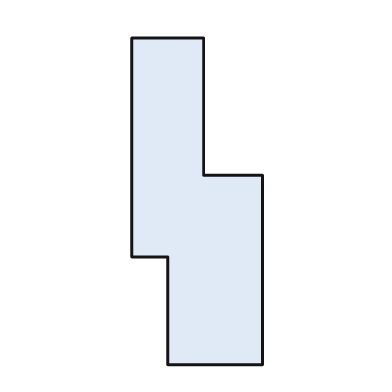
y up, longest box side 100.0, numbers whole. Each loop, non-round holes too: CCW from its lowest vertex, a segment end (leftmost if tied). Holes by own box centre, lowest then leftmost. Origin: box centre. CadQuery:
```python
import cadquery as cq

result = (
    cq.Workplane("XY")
    .moveTo(-9.0, -50.0)
    .lineTo(20.0, -50.0)
    .lineTo(20.0, 8.0)
    .lineTo(2.0, 8.0)
    .lineTo(2.0, 50.0)
    .lineTo(-20.0, 50.0)
    .lineTo(-20.0, -17.0)
    .lineTo(-9.0, -17.0)
    .close()
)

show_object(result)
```